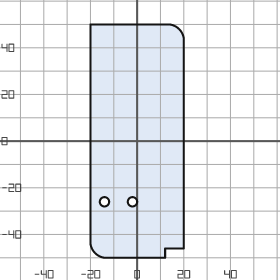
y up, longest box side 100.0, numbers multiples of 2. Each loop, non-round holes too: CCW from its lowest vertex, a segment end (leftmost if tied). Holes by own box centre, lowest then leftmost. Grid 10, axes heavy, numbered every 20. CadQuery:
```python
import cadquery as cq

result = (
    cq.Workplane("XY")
    .moveTo(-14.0, -50.0)
    .lineTo(12.0, -50.0)
    .lineTo(12.0, -46.0)
    .lineTo(20.0, -46.0)
    .lineTo(20.0, 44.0)
    .threePointArc((18.0, 48.0), (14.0, 50.0))
    .lineTo(-20.0, 50.0)
    .lineTo(-20.0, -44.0)
    .threePointArc((-18.0, -48.0), (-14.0, -50.0))
    .close()
    .moveTo(-14.0, -26.0)
    .circle(2.0)
    .moveTo(-2.0, -26.0)
    .circle(2.0)
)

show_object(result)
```